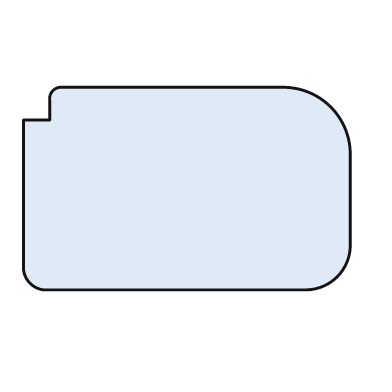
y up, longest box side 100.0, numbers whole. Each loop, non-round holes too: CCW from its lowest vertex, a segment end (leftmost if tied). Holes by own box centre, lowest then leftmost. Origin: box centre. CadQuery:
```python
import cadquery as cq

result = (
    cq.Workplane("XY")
    .moveTo(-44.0, -31.0)
    .lineTo(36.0, -31.0)
    .threePointArc((46.0, -27.0), (50.0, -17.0))
    .lineTo(50.0, 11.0)
    .threePointArc((44.0, 25.0), (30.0, 31.0))
    .lineTo(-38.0, 31.0)
    .threePointArc((-41.0, 30.0), (-42.0, 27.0))
    .lineTo(-42.0, 21.0)
    .lineTo(-50.0, 21.0)
    .lineTo(-50.0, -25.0)
    .threePointArc((-48.0, -29.0), (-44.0, -31.0))
    .close()
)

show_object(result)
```